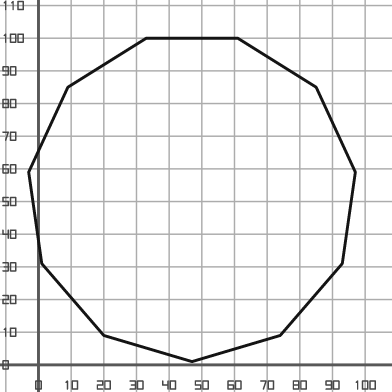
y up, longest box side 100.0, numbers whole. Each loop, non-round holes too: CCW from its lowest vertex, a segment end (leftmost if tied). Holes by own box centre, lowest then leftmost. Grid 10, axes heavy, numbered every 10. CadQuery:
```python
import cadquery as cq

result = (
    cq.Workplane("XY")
    .moveTo(47.0, 1.0)
    .lineTo(74.0, 9.0)
    .lineTo(93.0, 31.0)
    .lineTo(97.0, 59.0)
    .lineTo(85.0, 85.0)
    .lineTo(61.0, 100.0)
    .lineTo(33.0, 100.0)
    .lineTo(9.0, 85.0)
    .lineTo(-3.0, 59.0)
    .lineTo(1.0, 31.0)
    .lineTo(20.0, 9.0)
    .close()
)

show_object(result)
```